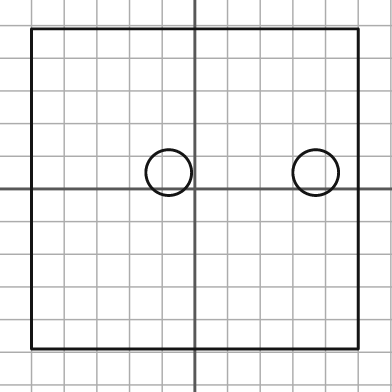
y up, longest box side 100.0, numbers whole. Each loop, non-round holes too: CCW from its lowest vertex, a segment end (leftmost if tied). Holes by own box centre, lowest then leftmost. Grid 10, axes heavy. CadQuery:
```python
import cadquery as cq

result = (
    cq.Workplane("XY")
    .moveTo(-50.0, -49.0)
    .lineTo(50.0, -49.0)
    .lineTo(50.0, 49.0)
    .lineTo(-50.0, 49.0)
    .close()
    .moveTo(-8.0, 5.0)
    .circle(7.0)
    .moveTo(37.0, 5.0)
    .circle(7.0)
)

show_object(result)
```